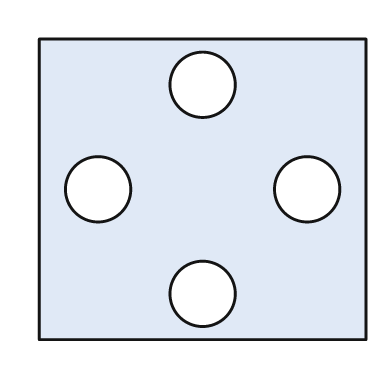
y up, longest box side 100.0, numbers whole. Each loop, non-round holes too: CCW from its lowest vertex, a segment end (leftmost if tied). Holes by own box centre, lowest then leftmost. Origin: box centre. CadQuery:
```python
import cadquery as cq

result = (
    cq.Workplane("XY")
    .moveTo(-50.0, -46.0)
    .lineTo(50.0, -46.0)
    .lineTo(50.0, 46.0)
    .lineTo(-50.0, 46.0)
    .close()
    .moveTo(0.0, -32.0)
    .circle(10.0)
    .moveTo(-32.0, 0.0)
    .circle(10.0)
    .moveTo(32.0, 0.0)
    .circle(10.0)
    .moveTo(0.0, 32.0)
    .circle(10.0)
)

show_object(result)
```